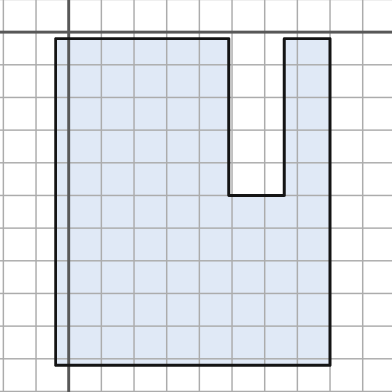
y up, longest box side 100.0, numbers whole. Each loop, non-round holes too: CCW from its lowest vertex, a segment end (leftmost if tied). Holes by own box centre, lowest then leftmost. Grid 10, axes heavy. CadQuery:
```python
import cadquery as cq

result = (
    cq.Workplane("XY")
    .moveTo(-4.0, -102.0)
    .lineTo(80.0, -102.0)
    .lineTo(80.0, -2.0)
    .lineTo(66.0, -2.0)
    .lineTo(66.0, -50.0)
    .lineTo(49.0, -50.0)
    .lineTo(49.0, -2.0)
    .lineTo(-4.0, -2.0)
    .close()
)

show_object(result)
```